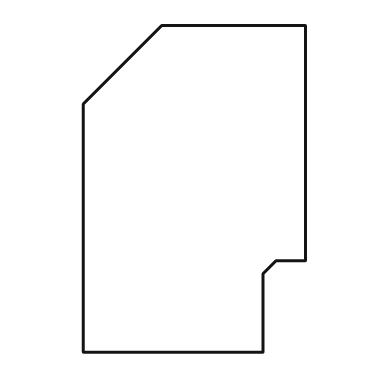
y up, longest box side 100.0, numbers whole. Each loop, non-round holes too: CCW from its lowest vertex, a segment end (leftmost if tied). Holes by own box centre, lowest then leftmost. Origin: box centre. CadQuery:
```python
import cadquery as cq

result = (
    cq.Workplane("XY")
    .moveTo(-34.0, -50.0)
    .lineTo(21.0, -50.0)
    .lineTo(21.0, -26.0)
    .lineTo(25.0, -22.0)
    .lineTo(34.0, -22.0)
    .lineTo(34.0, 50.0)
    .lineTo(-10.0, 50.0)
    .lineTo(-34.0, 26.0)
    .close()
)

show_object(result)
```